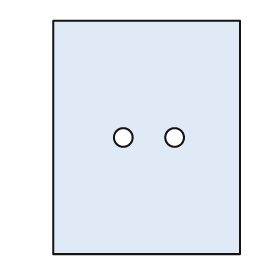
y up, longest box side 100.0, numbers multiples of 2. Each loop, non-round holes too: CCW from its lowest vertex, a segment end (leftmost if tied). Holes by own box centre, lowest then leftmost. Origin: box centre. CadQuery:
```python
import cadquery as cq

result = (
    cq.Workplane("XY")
    .moveTo(-40.0, -50.0)
    .lineTo(40.0, -50.0)
    .lineTo(40.0, 50.0)
    .lineTo(-40.0, 50.0)
    .close()
    .moveTo(-10.0, 0.0)
    .circle(4.0)
    .moveTo(12.0, 0.0)
    .circle(4.0)
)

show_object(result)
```